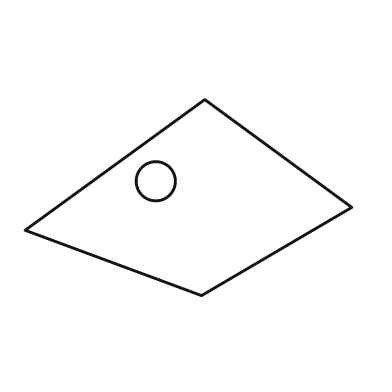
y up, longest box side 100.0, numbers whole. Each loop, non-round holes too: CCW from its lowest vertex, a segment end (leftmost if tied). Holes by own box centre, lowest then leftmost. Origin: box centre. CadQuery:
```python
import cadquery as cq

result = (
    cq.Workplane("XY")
    .moveTo(4.0, -30.0)
    .lineTo(50.0, -3.0)
    .lineTo(5.0, 30.0)
    .lineTo(-50.0, -10.0)
    .close()
    .moveTo(-10.0, 5.0)
    .circle(6.0)
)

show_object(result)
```